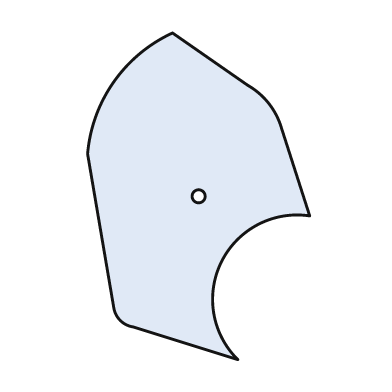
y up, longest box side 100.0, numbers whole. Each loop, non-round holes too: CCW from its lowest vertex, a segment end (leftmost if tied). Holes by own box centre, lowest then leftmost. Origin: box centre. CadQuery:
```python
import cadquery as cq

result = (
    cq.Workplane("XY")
    .moveTo(12.0, -50.0)
    .threePointArc((7.0, -20.0), (34.0, -6.0))
    .lineTo(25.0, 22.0)
    .threePointArc((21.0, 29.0), (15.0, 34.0))
    .lineTo(-8.0, 50.0)
    .threePointArc((-26.0, 35.0), (-34.0, 13.0))
    .lineTo(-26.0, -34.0)
    .threePointArc((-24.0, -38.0), (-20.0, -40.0))
    .close()
    .moveTo(0.0, 0.0)
    .circle(2.0)
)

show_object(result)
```